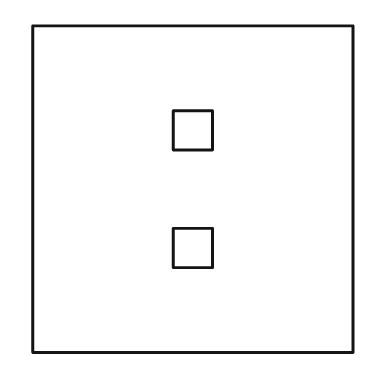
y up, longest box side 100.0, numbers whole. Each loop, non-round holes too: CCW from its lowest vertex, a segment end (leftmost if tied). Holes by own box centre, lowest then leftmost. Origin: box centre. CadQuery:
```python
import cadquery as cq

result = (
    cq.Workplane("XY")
    .moveTo(-49.0, -50.0)
    .lineTo(49.0, -50.0)
    .lineTo(49.0, 50.0)
    .lineTo(-49.0, 50.0)
    .close()
    .moveTo(-6.0, -24.0)
    .lineTo(6.0, -24.0)
    .lineTo(6.0, -12.0)
    .lineTo(-6.0, -12.0)
    .close()
    .moveTo(-6.0, 12.0)
    .lineTo(6.0, 12.0)
    .lineTo(6.0, 24.0)
    .lineTo(-6.0, 24.0)
    .close()
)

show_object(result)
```